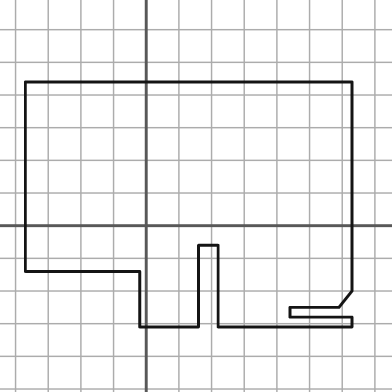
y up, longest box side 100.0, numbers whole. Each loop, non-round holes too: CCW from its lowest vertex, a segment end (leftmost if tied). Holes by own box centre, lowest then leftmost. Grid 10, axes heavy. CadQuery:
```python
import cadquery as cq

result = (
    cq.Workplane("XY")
    .moveTo(-2.0, -31.0)
    .lineTo(16.0, -31.0)
    .lineTo(16.0, -6.0)
    .lineTo(22.0, -6.0)
    .lineTo(22.0, -31.0)
    .lineTo(63.0, -31.0)
    .lineTo(63.0, -28.0)
    .lineTo(44.0, -28.0)
    .lineTo(44.0, -25.0)
    .lineTo(59.0, -25.0)
    .lineTo(63.0, -20.0)
    .lineTo(63.0, 44.0)
    .lineTo(-37.0, 44.0)
    .lineTo(-37.0, -14.0)
    .lineTo(-2.0, -14.0)
    .close()
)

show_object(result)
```